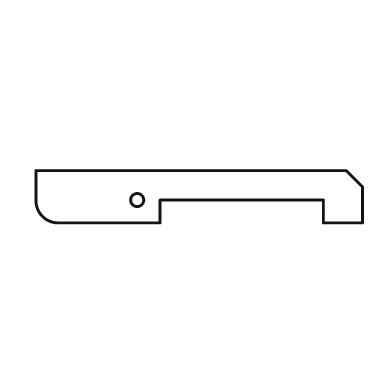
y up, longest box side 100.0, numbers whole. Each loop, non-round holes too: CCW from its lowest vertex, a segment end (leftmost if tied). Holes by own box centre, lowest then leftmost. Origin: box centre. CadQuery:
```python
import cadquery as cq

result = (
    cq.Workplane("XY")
    .moveTo(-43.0, -8.0)
    .lineTo(-12.0, -8.0)
    .lineTo(-12.0, -1.0)
    .lineTo(38.0, -1.0)
    .lineTo(38.0, -8.0)
    .lineTo(50.0, -8.0)
    .lineTo(50.0, 3.0)
    .lineTo(45.0, 8.0)
    .lineTo(-50.0, 8.0)
    .lineTo(-50.0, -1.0)
    .threePointArc((-48.0, -6.0), (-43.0, -8.0))
    .close()
    .moveTo(-19.0, -1.0)
    .circle(2.0)
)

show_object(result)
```